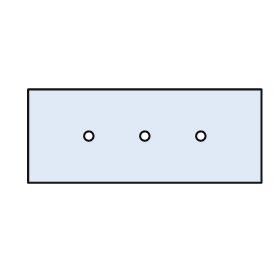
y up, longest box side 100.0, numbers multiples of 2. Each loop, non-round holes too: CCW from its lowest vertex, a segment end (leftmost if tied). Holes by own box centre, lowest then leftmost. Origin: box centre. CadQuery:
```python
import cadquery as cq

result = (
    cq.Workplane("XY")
    .moveTo(-50.0, -20.0)
    .lineTo(50.0, -20.0)
    .lineTo(50.0, 20.0)
    .lineTo(-50.0, 20.0)
    .close()
    .moveTo(-24.0, 0.0)
    .circle(2.0)
    .moveTo(0.0, 0.0)
    .circle(2.0)
    .moveTo(24.0, 0.0)
    .circle(2.0)
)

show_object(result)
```